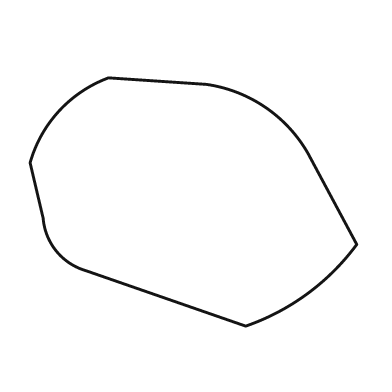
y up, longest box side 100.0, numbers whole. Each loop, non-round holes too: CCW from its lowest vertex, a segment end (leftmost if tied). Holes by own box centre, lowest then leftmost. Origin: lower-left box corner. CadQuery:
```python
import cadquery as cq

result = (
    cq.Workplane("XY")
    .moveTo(66.0, 0.0)
    .threePointArc((85.0, 10.0), (100.0, 25.0))
    .lineTo(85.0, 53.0)
    .threePointArc((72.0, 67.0), (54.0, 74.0))
    .lineTo(24.0, 76.0)
    .threePointArc((9.0, 66.0), (0.0, 50.0))
    .lineTo(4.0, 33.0)
    .threePointArc((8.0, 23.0), (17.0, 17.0))
    .close()
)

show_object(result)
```